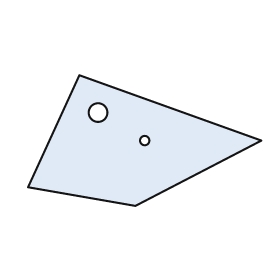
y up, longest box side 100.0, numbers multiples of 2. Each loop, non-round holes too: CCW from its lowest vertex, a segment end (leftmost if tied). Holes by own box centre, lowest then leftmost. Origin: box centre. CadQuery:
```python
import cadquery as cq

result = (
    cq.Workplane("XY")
    .moveTo(-4.0, -28.0)
    .lineTo(50.0, 0.0)
    .lineTo(-28.0, 28.0)
    .lineTo(-50.0, -20.0)
    .close()
    .moveTo(0.0, 0.0)
    .circle(2.0)
    .moveTo(-20.0, 12.0)
    .circle(4.0)
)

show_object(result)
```